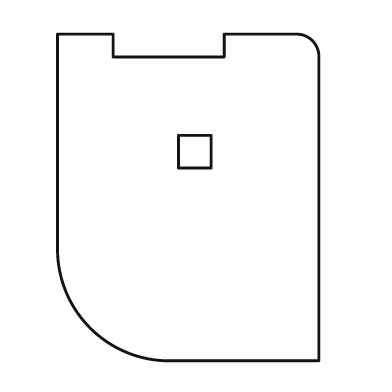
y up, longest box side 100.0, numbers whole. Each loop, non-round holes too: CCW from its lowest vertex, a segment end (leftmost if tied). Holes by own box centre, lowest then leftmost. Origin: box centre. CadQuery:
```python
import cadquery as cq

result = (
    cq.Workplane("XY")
    .moveTo(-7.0, -50.0)
    .lineTo(40.0, -50.0)
    .lineTo(40.0, 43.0)
    .threePointArc((38.0, 48.0), (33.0, 50.0))
    .lineTo(11.0, 50.0)
    .lineTo(11.0, 43.0)
    .lineTo(-23.0, 43.0)
    .lineTo(-23.0, 50.0)
    .lineTo(-40.0, 50.0)
    .lineTo(-40.0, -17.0)
    .threePointArc((-30.0, -40.0), (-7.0, -50.0))
    .close()
    .moveTo(-3.0, 9.0)
    .lineTo(7.0, 9.0)
    .lineTo(7.0, 19.0)
    .lineTo(-3.0, 19.0)
    .close()
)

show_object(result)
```